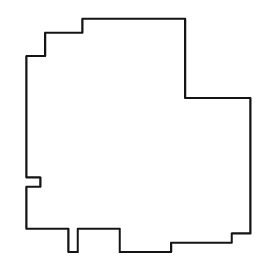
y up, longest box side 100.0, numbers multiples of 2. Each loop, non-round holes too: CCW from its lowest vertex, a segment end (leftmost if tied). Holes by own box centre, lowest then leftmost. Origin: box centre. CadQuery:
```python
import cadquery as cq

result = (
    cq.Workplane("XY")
    .moveTo(-30.0, -50.0)
    .lineTo(-26.0, -50.0)
    .lineTo(-26.0, -40.0)
    .lineTo(-8.0, -40.0)
    .lineTo(-8.0, -50.0)
    .lineTo(14.0, -50.0)
    .lineTo(14.0, -46.0)
    .lineTo(40.0, -46.0)
    .lineTo(40.0, -42.0)
    .lineTo(48.0, -42.0)
    .lineTo(48.0, 16.0)
    .lineTo(20.0, 16.0)
    .lineTo(20.0, 50.0)
    .lineTo(-24.0, 50.0)
    .lineTo(-24.0, 44.0)
    .lineTo(-40.0, 44.0)
    .lineTo(-40.0, 34.0)
    .lineTo(-48.0, 34.0)
    .lineTo(-48.0, -18.0)
    .lineTo(-42.0, -18.0)
    .lineTo(-42.0, -22.0)
    .lineTo(-48.0, -22.0)
    .lineTo(-48.0, -40.0)
    .lineTo(-30.0, -40.0)
    .close()
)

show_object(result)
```